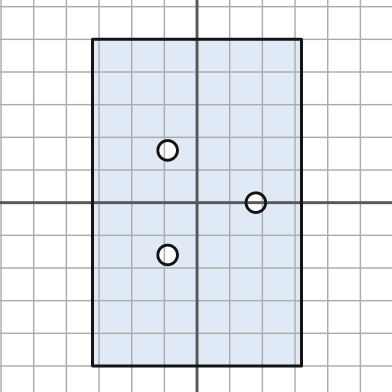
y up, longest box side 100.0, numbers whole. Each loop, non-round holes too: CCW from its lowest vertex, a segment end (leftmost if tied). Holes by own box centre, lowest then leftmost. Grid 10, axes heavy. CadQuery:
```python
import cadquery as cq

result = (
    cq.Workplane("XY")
    .moveTo(-32.0, -50.0)
    .lineTo(32.0, -50.0)
    .lineTo(32.0, 50.0)
    .lineTo(-32.0, 50.0)
    .close()
    .moveTo(-9.0, -16.0)
    .circle(3.0)
    .moveTo(18.0, 0.0)
    .circle(3.0)
    .moveTo(-9.0, 16.0)
    .circle(3.0)
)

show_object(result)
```